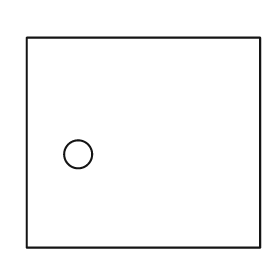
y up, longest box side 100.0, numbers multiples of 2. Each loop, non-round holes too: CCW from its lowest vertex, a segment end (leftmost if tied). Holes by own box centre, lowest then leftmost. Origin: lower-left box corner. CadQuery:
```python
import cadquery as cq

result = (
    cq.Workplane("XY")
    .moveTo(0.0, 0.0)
    .lineTo(100.0, 0.0)
    .lineTo(100.0, 90.0)
    .lineTo(0.0, 90.0)
    .close()
    .moveTo(22.0, 40.0)
    .circle(6.0)
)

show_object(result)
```